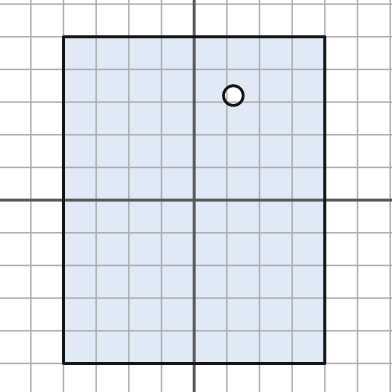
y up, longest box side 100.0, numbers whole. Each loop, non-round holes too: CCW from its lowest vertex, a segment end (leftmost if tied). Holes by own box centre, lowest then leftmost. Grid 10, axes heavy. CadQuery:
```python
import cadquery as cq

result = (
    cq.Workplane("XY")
    .moveTo(-40.0, -50.0)
    .lineTo(40.0, -50.0)
    .lineTo(40.0, 50.0)
    .lineTo(-40.0, 50.0)
    .close()
    .moveTo(12.0, 32.0)
    .circle(3.0)
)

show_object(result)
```